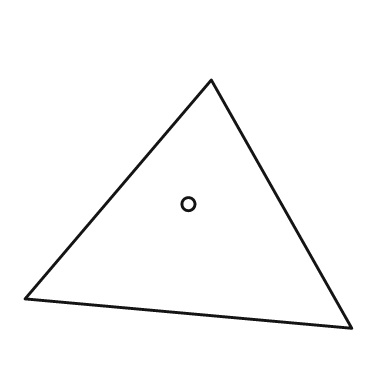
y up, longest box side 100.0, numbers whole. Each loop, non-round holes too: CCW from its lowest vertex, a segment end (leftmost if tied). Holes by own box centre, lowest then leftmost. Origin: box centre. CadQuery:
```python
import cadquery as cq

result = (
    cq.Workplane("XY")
    .moveTo(50.0, -38.0)
    .lineTo(7.0, 38.0)
    .lineTo(-50.0, -29.0)
    .close()
    .moveTo(0.0, 0.0)
    .circle(2.0)
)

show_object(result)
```